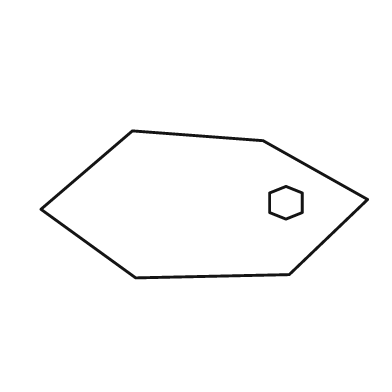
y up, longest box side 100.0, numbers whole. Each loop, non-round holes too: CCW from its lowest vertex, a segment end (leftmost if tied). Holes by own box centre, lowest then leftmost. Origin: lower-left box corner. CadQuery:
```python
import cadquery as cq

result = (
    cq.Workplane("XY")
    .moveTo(29.0, 0.0)
    .lineTo(76.0, 1.0)
    .lineTo(100.0, 24.0)
    .lineTo(68.0, 42.0)
    .lineTo(28.0, 45.0)
    .lineTo(0.0, 21.0)
    .close()
    .moveTo(75.0, 18.0)
    .lineTo(80.0, 20.0)
    .lineTo(80.0, 26.0)
    .lineTo(75.0, 28.0)
    .lineTo(70.0, 26.0)
    .lineTo(70.0, 20.0)
    .close()
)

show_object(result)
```